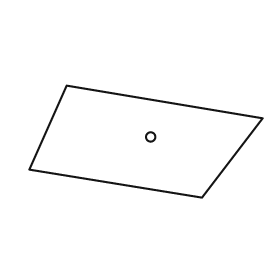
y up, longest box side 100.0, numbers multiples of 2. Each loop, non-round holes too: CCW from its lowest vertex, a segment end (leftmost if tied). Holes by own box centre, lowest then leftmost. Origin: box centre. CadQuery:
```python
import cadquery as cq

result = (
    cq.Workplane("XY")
    .moveTo(24.0, -24.0)
    .lineTo(50.0, 10.0)
    .lineTo(-34.0, 24.0)
    .lineTo(-50.0, -12.0)
    .close()
    .moveTo(2.0, 2.0)
    .circle(2.0)
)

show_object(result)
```